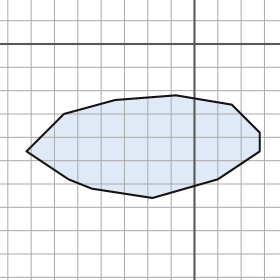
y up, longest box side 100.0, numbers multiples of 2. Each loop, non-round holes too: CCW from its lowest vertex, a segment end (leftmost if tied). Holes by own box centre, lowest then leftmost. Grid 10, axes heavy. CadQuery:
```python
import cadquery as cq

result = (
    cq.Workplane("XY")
    .moveTo(-18.0, -66.0)
    .lineTo(10.0, -58.0)
    .lineTo(28.0, -46.0)
    .lineTo(28.0, -38.0)
    .lineTo(16.0, -26.0)
    .lineTo(-8.0, -22.0)
    .lineTo(-34.0, -24.0)
    .lineTo(-56.0, -30.0)
    .lineTo(-72.0, -46.0)
    .lineTo(-54.0, -58.0)
    .lineTo(-44.0, -62.0)
    .close()
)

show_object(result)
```